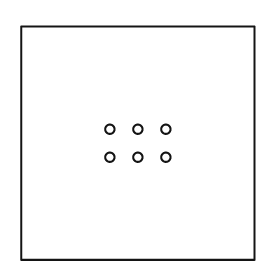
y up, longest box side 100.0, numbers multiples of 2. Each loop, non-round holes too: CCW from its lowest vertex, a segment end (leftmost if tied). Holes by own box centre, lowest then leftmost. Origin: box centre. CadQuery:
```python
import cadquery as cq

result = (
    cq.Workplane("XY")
    .moveTo(-50.0, -50.0)
    .lineTo(50.0, -50.0)
    .lineTo(50.0, 50.0)
    .lineTo(-50.0, 50.0)
    .close()
    .moveTo(-12.0, -6.0)
    .circle(2.0)
    .moveTo(0.0, -6.0)
    .circle(2.0)
    .moveTo(12.0, -6.0)
    .circle(2.0)
    .moveTo(-12.0, 6.0)
    .circle(2.0)
    .moveTo(0.0, 6.0)
    .circle(2.0)
    .moveTo(12.0, 6.0)
    .circle(2.0)
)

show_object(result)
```